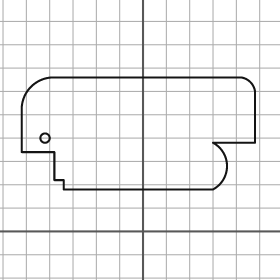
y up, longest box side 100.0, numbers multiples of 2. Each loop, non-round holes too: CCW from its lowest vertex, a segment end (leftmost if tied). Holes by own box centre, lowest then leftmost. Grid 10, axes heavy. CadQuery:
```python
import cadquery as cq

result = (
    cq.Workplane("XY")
    .moveTo(-34.0, 18.0)
    .lineTo(30.0, 18.0)
    .threePointArc((36.0, 28.0), (30.0, 38.0))
    .lineTo(48.0, 38.0)
    .lineTo(48.0, 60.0)
    .threePointArc((46.0, 64.0), (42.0, 66.0))
    .lineTo(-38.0, 66.0)
    .threePointArc((-48.0, 62.0), (-52.0, 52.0))
    .lineTo(-52.0, 34.0)
    .lineTo(-38.0, 34.0)
    .lineTo(-38.0, 22.0)
    .lineTo(-34.0, 22.0)
    .close()
    .moveTo(-42.0, 40.0)
    .circle(2.0)
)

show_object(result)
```